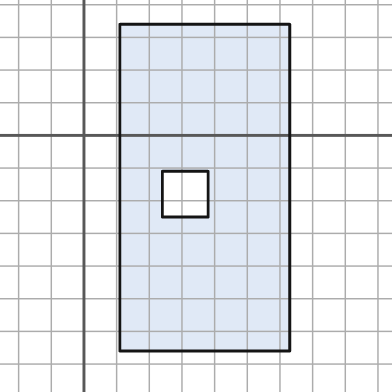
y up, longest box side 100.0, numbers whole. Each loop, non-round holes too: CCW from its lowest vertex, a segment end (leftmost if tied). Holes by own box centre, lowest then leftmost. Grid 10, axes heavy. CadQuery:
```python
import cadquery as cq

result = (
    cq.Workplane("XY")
    .moveTo(11.0, -66.0)
    .lineTo(63.0, -66.0)
    .lineTo(63.0, 34.0)
    .lineTo(11.0, 34.0)
    .close()
    .moveTo(24.0, -25.0)
    .lineTo(38.0, -25.0)
    .lineTo(38.0, -11.0)
    .lineTo(24.0, -11.0)
    .close()
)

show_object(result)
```